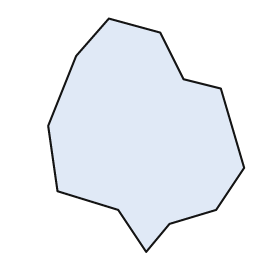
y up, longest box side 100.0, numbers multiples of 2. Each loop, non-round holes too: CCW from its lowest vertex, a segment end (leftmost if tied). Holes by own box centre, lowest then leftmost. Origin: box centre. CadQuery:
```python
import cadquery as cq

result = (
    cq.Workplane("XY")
    .moveTo(0.0, -50.0)
    .lineTo(10.0, -38.0)
    .lineTo(30.0, -32.0)
    .lineTo(42.0, -14.0)
    .lineTo(32.0, 20.0)
    .lineTo(16.0, 24.0)
    .lineTo(6.0, 44.0)
    .lineTo(-16.0, 50.0)
    .lineTo(-30.0, 34.0)
    .lineTo(-42.0, 4.0)
    .lineTo(-38.0, -24.0)
    .lineTo(-12.0, -32.0)
    .close()
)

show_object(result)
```